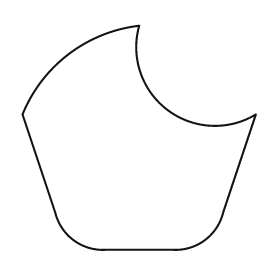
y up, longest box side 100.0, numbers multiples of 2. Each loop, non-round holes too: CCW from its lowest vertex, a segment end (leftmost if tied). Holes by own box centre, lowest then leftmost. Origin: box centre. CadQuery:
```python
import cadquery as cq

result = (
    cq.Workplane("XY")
    .moveTo(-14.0, -48.0)
    .lineTo(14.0, -48.0)
    .threePointArc((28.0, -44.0), (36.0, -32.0))
    .lineTo(50.0, 10.0)
    .threePointArc((12.0, 12.0), (0.0, 48.0))
    .threePointArc((-30.0, 36.0), (-50.0, 10.0))
    .lineTo(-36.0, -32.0)
    .threePointArc((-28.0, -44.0), (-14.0, -48.0))
    .close()
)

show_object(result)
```